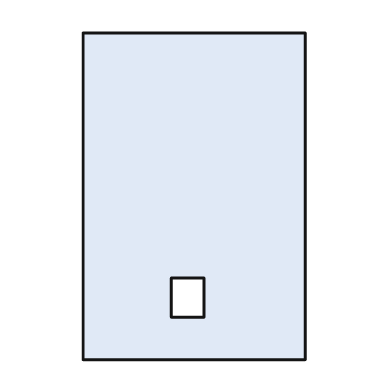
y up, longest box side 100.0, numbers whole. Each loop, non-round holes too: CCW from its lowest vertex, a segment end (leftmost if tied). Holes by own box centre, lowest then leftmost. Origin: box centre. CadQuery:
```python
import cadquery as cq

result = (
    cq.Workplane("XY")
    .moveTo(-34.0, -50.0)
    .lineTo(34.0, -50.0)
    .lineTo(34.0, 50.0)
    .lineTo(-34.0, 50.0)
    .close()
    .moveTo(-7.0, -37.0)
    .lineTo(3.0, -37.0)
    .lineTo(3.0, -25.0)
    .lineTo(-7.0, -25.0)
    .close()
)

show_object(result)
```